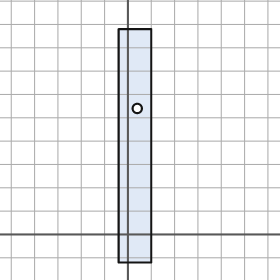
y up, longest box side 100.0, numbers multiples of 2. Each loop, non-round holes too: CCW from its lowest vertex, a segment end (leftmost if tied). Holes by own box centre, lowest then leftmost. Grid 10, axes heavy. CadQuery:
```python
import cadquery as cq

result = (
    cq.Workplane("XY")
    .moveTo(-4.0, -12.0)
    .lineTo(10.0, -12.0)
    .lineTo(10.0, 88.0)
    .lineTo(-4.0, 88.0)
    .close()
    .moveTo(4.0, 54.0)
    .circle(2.0)
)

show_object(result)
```